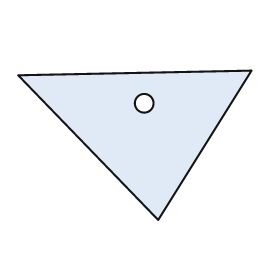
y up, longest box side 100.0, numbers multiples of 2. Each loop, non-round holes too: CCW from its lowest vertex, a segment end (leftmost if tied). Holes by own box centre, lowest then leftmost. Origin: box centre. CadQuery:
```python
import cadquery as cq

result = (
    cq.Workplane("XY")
    .moveTo(10.0, -32.0)
    .lineTo(50.0, 32.0)
    .lineTo(-50.0, 30.0)
    .close()
    .moveTo(4.0, 18.0)
    .circle(4.0)
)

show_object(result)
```